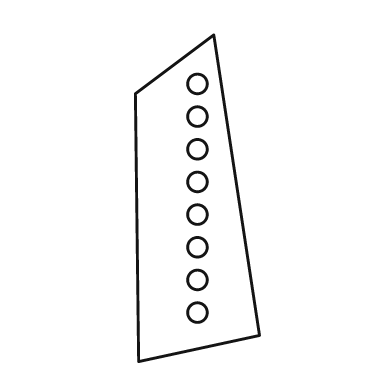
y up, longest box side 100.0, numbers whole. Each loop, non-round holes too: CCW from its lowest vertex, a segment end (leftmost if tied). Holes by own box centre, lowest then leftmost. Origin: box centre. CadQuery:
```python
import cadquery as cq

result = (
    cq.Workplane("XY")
    .moveTo(-18.0, -50.0)
    .lineTo(19.0, -42.0)
    .lineTo(5.0, 50.0)
    .lineTo(-19.0, 32.0)
    .close()
    .moveTo(0.0, -35.0)
    .circle(3.0)
    .moveTo(0.0, -25.0)
    .circle(3.0)
    .moveTo(0.0, -15.0)
    .circle(3.0)
    .moveTo(0.0, -5.0)
    .circle(3.0)
    .moveTo(0.0, 5.0)
    .circle(3.0)
    .moveTo(0.0, 15.0)
    .circle(3.0)
    .moveTo(0.0, 25.0)
    .circle(3.0)
    .moveTo(0.0, 35.0)
    .circle(3.0)
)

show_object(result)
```